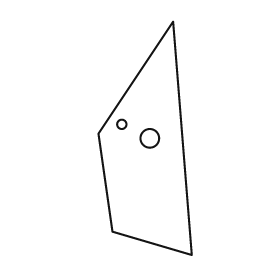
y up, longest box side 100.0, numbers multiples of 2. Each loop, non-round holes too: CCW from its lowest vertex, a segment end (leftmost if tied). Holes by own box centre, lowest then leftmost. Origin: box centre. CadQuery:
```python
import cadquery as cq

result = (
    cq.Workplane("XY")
    .moveTo(20.0, -50.0)
    .lineTo(12.0, 50.0)
    .lineTo(-20.0, 2.0)
    .lineTo(-14.0, -40.0)
    .close()
    .moveTo(2.0, 0.0)
    .circle(4.0)
    .moveTo(-10.0, 6.0)
    .circle(2.0)
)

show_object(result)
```